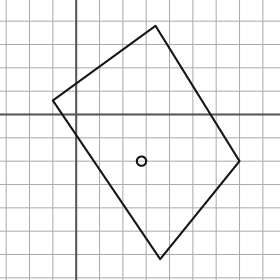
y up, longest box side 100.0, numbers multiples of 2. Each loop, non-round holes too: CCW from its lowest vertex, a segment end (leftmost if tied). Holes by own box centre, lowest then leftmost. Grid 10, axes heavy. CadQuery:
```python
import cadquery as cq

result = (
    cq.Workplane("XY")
    .moveTo(36.0, -62.0)
    .lineTo(70.0, -20.0)
    .lineTo(34.0, 38.0)
    .lineTo(-10.0, 6.0)
    .close()
    .moveTo(28.0, -20.0)
    .circle(2.0)
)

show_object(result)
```